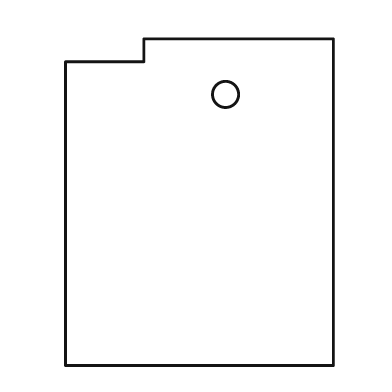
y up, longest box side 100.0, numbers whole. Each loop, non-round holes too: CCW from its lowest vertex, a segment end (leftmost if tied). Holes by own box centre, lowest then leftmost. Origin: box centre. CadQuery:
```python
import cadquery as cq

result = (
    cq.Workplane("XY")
    .moveTo(-41.0, -50.0)
    .lineTo(41.0, -50.0)
    .lineTo(41.0, 50.0)
    .lineTo(-17.0, 50.0)
    .lineTo(-17.0, 43.0)
    .lineTo(-41.0, 43.0)
    .close()
    .moveTo(8.0, 33.0)
    .circle(4.0)
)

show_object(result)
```